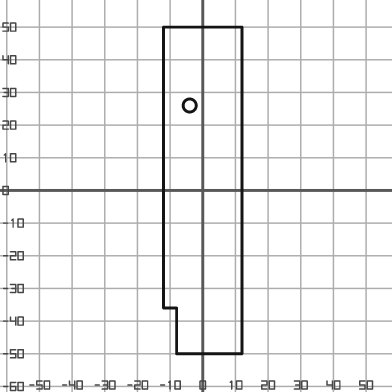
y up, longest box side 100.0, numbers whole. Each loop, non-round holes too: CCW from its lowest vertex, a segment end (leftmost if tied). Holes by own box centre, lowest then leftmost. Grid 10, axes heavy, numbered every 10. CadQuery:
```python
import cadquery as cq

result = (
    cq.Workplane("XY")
    .moveTo(-8.0, -50.0)
    .lineTo(12.0, -50.0)
    .lineTo(12.0, 50.0)
    .lineTo(-12.0, 50.0)
    .lineTo(-12.0, -36.0)
    .lineTo(-8.0, -36.0)
    .close()
    .moveTo(-4.0, 26.0)
    .circle(2.0)
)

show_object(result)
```